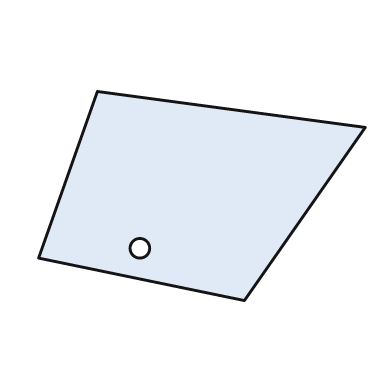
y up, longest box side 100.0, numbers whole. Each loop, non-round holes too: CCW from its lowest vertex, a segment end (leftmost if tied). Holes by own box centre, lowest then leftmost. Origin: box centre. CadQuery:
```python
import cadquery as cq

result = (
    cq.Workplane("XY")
    .moveTo(13.0, -32.0)
    .lineTo(50.0, 21.0)
    .lineTo(-32.0, 32.0)
    .lineTo(-50.0, -19.0)
    .close()
    .moveTo(-19.0, -16.0)
    .circle(3.0)
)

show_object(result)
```